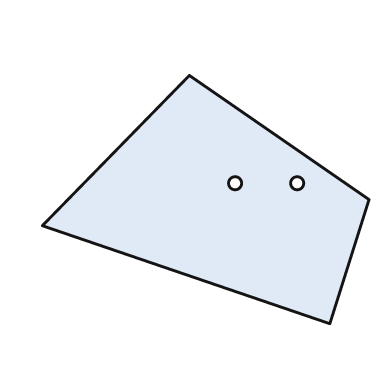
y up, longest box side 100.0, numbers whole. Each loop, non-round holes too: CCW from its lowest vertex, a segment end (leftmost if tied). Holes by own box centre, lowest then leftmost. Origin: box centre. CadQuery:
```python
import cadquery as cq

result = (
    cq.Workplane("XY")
    .moveTo(38.0, -38.0)
    .lineTo(50.0, 0.0)
    .lineTo(-5.0, 38.0)
    .lineTo(-50.0, -8.0)
    .close()
    .moveTo(9.0, 5.0)
    .circle(2.0)
    .moveTo(28.0, 5.0)
    .circle(2.0)
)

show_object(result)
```